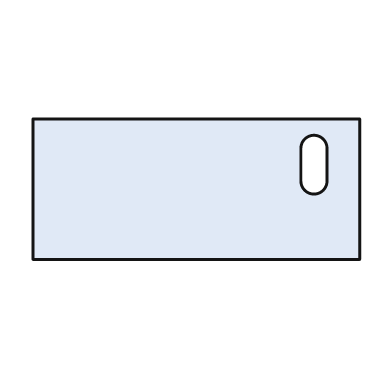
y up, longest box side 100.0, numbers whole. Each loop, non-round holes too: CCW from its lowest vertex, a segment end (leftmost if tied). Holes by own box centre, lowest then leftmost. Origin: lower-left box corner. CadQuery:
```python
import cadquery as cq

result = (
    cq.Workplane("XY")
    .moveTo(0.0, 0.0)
    .lineTo(100.0, 0.0)
    .lineTo(100.0, 43.0)
    .lineTo(0.0, 43.0)
    .close()
    .moveTo(82.0, 24.0)
    .threePointArc((86.0, 20.0), (90.0, 24.0))
    .lineTo(90.0, 34.0)
    .threePointArc((86.0, 38.0), (82.0, 34.0))
    .close()
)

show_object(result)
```